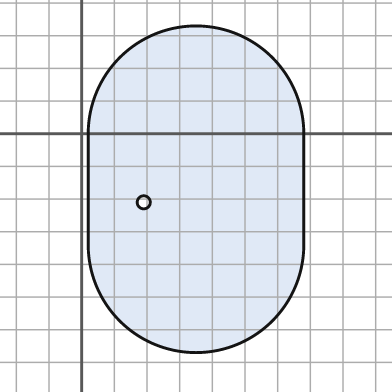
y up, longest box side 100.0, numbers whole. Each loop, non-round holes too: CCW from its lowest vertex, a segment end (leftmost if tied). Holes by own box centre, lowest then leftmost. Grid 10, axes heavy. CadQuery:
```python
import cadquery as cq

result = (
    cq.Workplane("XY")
    .moveTo(2.0, -34.0)
    .threePointArc((35.0, -67.0), (68.0, -34.0))
    .lineTo(68.0, 0.0)
    .threePointArc((35.0, 33.0), (2.0, 0.0))
    .close()
    .moveTo(19.0, -21.0)
    .circle(2.0)
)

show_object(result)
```